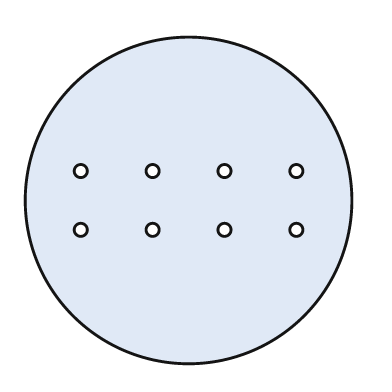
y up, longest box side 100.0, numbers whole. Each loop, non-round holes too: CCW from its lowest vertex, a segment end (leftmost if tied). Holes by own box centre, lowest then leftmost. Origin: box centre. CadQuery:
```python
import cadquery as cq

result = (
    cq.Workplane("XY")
    .moveTo(0.0, 0.0)
    .circle(50.0)
    .moveTo(-33.0, -9.0)
    .circle(2.0)
    .moveTo(-11.0, -9.0)
    .circle(2.0)
    .moveTo(11.0, -9.0)
    .circle(2.0)
    .moveTo(33.0, -9.0)
    .circle(2.0)
    .moveTo(-33.0, 9.0)
    .circle(2.0)
    .moveTo(-11.0, 9.0)
    .circle(2.0)
    .moveTo(11.0, 9.0)
    .circle(2.0)
    .moveTo(33.0, 9.0)
    .circle(2.0)
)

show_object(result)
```